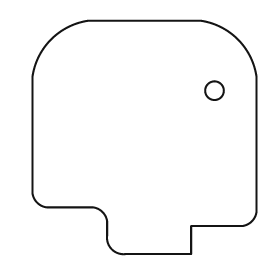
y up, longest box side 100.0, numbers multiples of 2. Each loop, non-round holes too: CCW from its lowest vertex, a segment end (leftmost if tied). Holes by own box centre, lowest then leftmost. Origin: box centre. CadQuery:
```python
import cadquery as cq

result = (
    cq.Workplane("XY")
    .moveTo(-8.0, -50.0)
    .lineTo(20.0, -50.0)
    .lineTo(20.0, -38.0)
    .lineTo(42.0, -38.0)
    .threePointArc((46.0, -36.0), (48.0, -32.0))
    .lineTo(48.0, 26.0)
    .threePointArc((40.0, 42.0), (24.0, 50.0))
    .lineTo(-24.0, 50.0)
    .threePointArc((-40.0, 42.0), (-48.0, 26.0))
    .lineTo(-48.0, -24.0)
    .threePointArc((-46.0, -28.0), (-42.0, -30.0))
    .lineTo(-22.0, -30.0)
    .threePointArc((-18.0, -32.0), (-16.0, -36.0))
    .lineTo(-16.0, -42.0)
    .threePointArc((-14.0, -48.0), (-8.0, -50.0))
    .close()
    .moveTo(30.0, 20.0)
    .circle(4.0)
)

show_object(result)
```